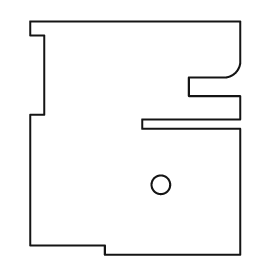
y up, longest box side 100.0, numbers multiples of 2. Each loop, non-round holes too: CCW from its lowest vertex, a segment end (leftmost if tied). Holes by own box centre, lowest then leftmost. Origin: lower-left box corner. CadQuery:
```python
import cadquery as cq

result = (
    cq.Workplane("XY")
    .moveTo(32.0, 0.0)
    .lineTo(90.0, 0.0)
    .lineTo(90.0, 54.0)
    .lineTo(48.0, 54.0)
    .lineTo(48.0, 58.0)
    .lineTo(90.0, 58.0)
    .lineTo(90.0, 68.0)
    .lineTo(68.0, 68.0)
    .lineTo(68.0, 76.0)
    .lineTo(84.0, 76.0)
    .threePointArc((88.0, 78.0), (90.0, 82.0))
    .lineTo(90.0, 100.0)
    .lineTo(0.0, 100.0)
    .lineTo(0.0, 94.0)
    .lineTo(6.0, 94.0)
    .lineTo(6.0, 60.0)
    .lineTo(0.0, 60.0)
    .lineTo(0.0, 4.0)
    .lineTo(32.0, 4.0)
    .close()
    .moveTo(56.0, 30.0)
    .circle(4.0)
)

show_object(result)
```